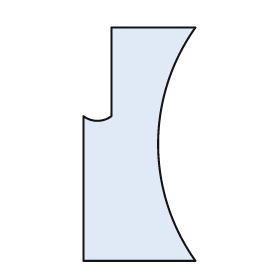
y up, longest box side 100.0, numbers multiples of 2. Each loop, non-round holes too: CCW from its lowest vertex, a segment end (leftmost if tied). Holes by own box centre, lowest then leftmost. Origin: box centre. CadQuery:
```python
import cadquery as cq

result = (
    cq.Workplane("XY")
    .moveTo(-24.0, -50.0)
    .lineTo(24.0, -50.0)
    .threePointArc((8.0, 0.0), (24.0, 50.0))
    .lineTo(-12.0, 50.0)
    .lineTo(-12.0, 12.0)
    .threePointArc((-18.0, 10.0), (-24.0, 12.0))
    .close()
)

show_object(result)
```